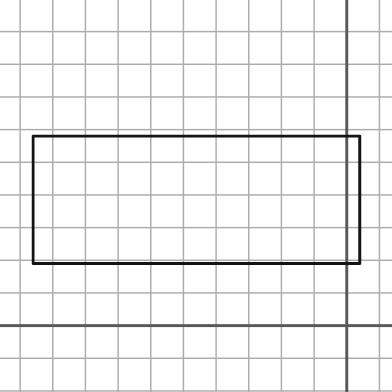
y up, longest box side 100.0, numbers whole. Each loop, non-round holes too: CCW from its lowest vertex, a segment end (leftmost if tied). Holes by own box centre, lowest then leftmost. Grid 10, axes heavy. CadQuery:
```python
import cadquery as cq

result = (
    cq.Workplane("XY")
    .moveTo(-96.0, 19.0)
    .lineTo(4.0, 19.0)
    .lineTo(4.0, 58.0)
    .lineTo(-96.0, 58.0)
    .close()
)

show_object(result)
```